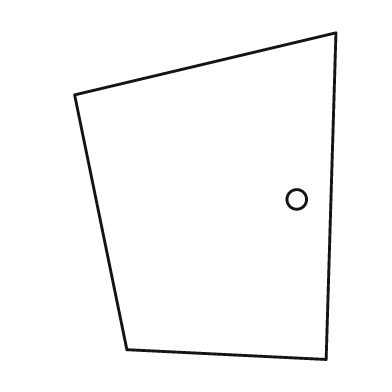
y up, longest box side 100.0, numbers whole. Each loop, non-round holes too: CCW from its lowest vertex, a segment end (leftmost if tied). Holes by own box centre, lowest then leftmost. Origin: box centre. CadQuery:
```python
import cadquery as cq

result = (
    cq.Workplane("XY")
    .moveTo(37.0, -50.0)
    .lineTo(40.0, 50.0)
    .lineTo(-40.0, 31.0)
    .lineTo(-24.0, -47.0)
    .close()
    .moveTo(28.0, -1.0)
    .circle(3.0)
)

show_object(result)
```